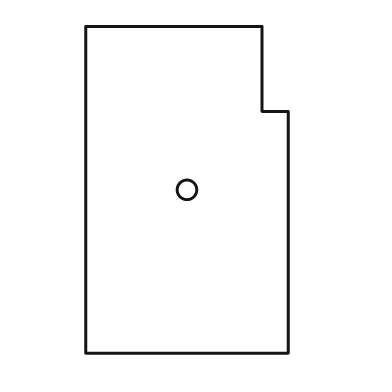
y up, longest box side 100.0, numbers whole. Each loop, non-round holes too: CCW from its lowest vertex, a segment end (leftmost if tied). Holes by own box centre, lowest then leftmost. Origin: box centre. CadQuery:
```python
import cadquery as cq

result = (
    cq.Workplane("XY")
    .moveTo(-31.0, -50.0)
    .lineTo(31.0, -50.0)
    .lineTo(31.0, 24.0)
    .lineTo(23.0, 24.0)
    .lineTo(23.0, 50.0)
    .lineTo(-31.0, 50.0)
    .close()
    .moveTo(0.0, 0.0)
    .circle(3.0)
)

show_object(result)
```